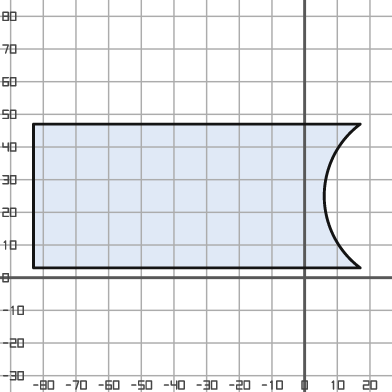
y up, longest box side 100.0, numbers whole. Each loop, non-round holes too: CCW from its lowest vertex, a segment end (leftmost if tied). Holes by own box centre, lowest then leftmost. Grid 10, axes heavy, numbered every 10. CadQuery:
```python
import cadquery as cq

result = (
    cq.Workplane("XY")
    .moveTo(-83.0, 3.0)
    .lineTo(17.0, 3.0)
    .threePointArc((6.0, 25.0), (17.0, 47.0))
    .lineTo(-83.0, 47.0)
    .close()
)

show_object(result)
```